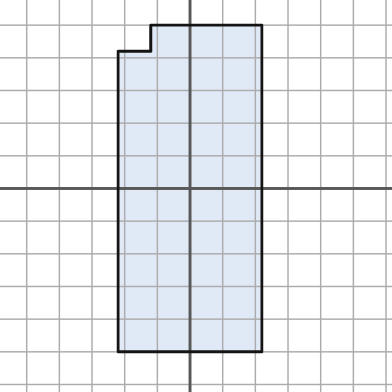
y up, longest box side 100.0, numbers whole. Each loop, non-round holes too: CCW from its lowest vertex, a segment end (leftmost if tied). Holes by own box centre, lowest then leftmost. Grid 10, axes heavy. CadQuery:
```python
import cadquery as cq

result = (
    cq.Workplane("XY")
    .moveTo(-22.0, -50.0)
    .lineTo(22.0, -50.0)
    .lineTo(22.0, 50.0)
    .lineTo(-12.0, 50.0)
    .lineTo(-12.0, 42.0)
    .lineTo(-22.0, 42.0)
    .close()
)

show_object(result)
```